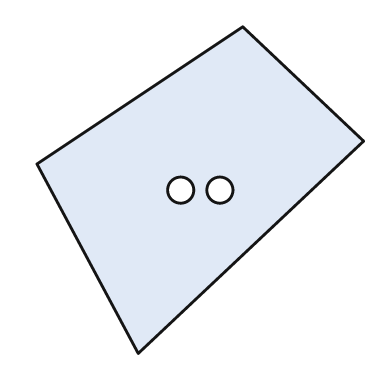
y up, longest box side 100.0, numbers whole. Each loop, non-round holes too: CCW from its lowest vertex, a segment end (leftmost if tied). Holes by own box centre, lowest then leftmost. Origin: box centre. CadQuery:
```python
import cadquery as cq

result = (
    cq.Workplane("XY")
    .moveTo(-19.0, -50.0)
    .lineTo(50.0, 15.0)
    .lineTo(13.0, 50.0)
    .lineTo(-50.0, 8.0)
    .close()
    .moveTo(-6.0, 0.0)
    .circle(4.0)
    .moveTo(6.0, 0.0)
    .circle(4.0)
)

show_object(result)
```